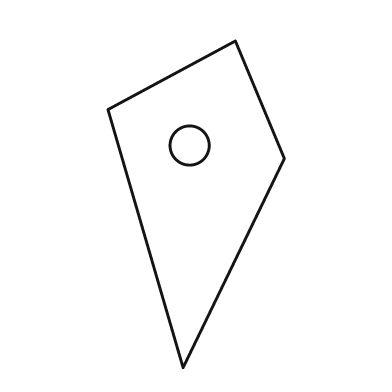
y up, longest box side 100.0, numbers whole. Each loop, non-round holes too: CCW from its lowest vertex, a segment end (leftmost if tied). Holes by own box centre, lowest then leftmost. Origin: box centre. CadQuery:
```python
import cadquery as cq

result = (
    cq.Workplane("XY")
    .moveTo(-4.0, -50.0)
    .lineTo(27.0, 14.0)
    .lineTo(12.0, 50.0)
    .lineTo(-27.0, 29.0)
    .close()
    .moveTo(-2.0, 18.0)
    .circle(6.0)
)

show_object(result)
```